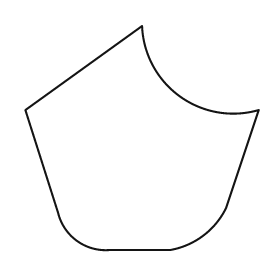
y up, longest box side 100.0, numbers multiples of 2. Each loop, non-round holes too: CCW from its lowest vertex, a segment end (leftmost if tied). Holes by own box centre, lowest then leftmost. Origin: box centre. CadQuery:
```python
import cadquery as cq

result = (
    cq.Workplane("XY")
    .moveTo(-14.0, -48.0)
    .lineTo(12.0, -48.0)
    .threePointArc((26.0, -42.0), (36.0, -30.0))
    .lineTo(50.0, 12.0)
    .threePointArc((16.0, 18.0), (0.0, 48.0))
    .lineTo(-50.0, 12.0)
    .lineTo(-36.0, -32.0)
    .threePointArc((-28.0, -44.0), (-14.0, -48.0))
    .close()
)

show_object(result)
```